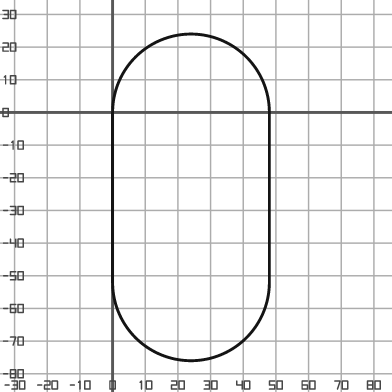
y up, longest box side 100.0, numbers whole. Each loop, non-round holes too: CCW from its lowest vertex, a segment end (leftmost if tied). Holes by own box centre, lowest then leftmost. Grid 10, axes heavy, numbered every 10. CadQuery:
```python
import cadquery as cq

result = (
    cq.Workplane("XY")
    .moveTo(0.0, -52.0)
    .threePointArc((24.0, -76.0), (48.0, -52.0))
    .lineTo(48.0, 0.0)
    .threePointArc((24.0, 24.0), (0.0, 0.0))
    .close()
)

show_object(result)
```